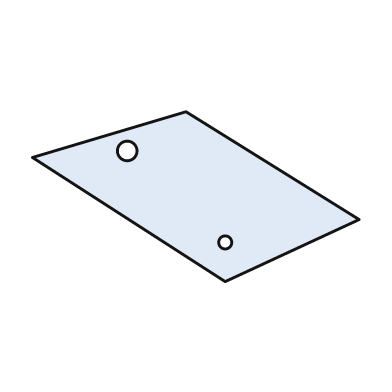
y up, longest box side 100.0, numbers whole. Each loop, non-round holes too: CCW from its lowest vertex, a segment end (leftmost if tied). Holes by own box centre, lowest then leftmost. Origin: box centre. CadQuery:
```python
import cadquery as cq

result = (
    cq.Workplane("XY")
    .moveTo(9.0, -26.0)
    .lineTo(50.0, -7.0)
    .lineTo(-3.0, 26.0)
    .lineTo(-50.0, 12.0)
    .close()
    .moveTo(9.0, -14.0)
    .circle(2.0)
    .moveTo(-21.0, 14.0)
    .circle(3.0)
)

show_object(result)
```